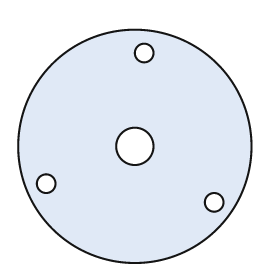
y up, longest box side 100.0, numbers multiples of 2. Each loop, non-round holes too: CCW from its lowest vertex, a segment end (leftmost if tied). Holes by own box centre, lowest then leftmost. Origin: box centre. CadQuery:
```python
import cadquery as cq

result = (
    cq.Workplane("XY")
    .moveTo(0.0, 0.0)
    .circle(50.0)
    .moveTo(34.0, -24.0)
    .circle(4.0)
    .moveTo(-38.0, -16.0)
    .circle(4.0)
    .moveTo(0.0, 0.0)
    .circle(8.0)
    .moveTo(4.0, 40.0)
    .circle(4.0)
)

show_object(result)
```